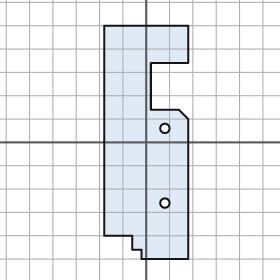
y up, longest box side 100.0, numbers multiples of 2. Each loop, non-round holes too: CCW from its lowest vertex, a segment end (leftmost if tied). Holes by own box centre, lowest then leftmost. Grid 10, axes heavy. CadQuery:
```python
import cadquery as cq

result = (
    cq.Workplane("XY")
    .moveTo(-2.0, -50.0)
    .lineTo(18.0, -50.0)
    .lineTo(18.0, 10.0)
    .lineTo(14.0, 14.0)
    .lineTo(2.0, 14.0)
    .lineTo(2.0, 34.0)
    .lineTo(18.0, 34.0)
    .lineTo(18.0, 50.0)
    .lineTo(-18.0, 50.0)
    .lineTo(-18.0, -40.0)
    .lineTo(-6.0, -40.0)
    .lineTo(-6.0, -46.0)
    .lineTo(-2.0, -46.0)
    .close()
    .moveTo(8.0, -26.0)
    .circle(2.0)
    .moveTo(8.0, 6.0)
    .circle(2.0)
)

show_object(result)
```